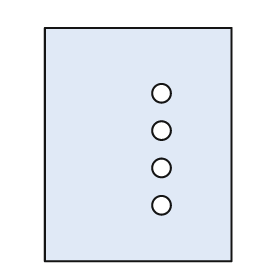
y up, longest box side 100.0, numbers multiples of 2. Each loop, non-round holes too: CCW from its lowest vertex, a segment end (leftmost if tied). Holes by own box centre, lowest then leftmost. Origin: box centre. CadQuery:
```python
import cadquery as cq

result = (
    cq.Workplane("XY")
    .moveTo(-40.0, -50.0)
    .lineTo(40.0, -50.0)
    .lineTo(40.0, 50.0)
    .lineTo(-40.0, 50.0)
    .close()
    .moveTo(10.0, -26.0)
    .circle(4.0)
    .moveTo(10.0, -10.0)
    .circle(4.0)
    .moveTo(10.0, 6.0)
    .circle(4.0)
    .moveTo(10.0, 22.0)
    .circle(4.0)
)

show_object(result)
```